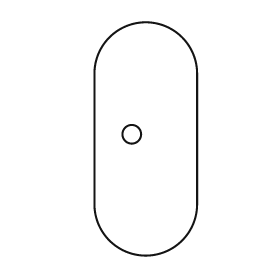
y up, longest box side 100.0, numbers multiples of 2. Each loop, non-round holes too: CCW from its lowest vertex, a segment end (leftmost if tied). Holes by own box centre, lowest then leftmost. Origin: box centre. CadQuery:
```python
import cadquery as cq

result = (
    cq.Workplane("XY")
    .moveTo(-22.0, -28.0)
    .threePointArc((0.0, -50.0), (22.0, -28.0))
    .lineTo(22.0, 28.0)
    .threePointArc((0.0, 50.0), (-22.0, 28.0))
    .close()
    .moveTo(-6.0, 2.0)
    .circle(4.0)
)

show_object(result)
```